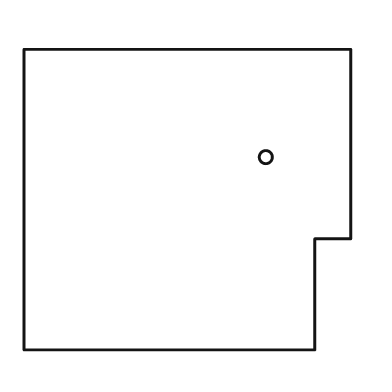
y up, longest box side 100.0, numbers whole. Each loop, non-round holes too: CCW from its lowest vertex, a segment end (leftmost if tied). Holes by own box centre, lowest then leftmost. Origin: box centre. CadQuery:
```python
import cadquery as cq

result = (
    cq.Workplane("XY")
    .moveTo(-50.0, -46.0)
    .lineTo(39.0, -46.0)
    .lineTo(39.0, -12.0)
    .lineTo(50.0, -12.0)
    .lineTo(50.0, 46.0)
    .lineTo(-50.0, 46.0)
    .close()
    .moveTo(24.0, 13.0)
    .circle(2.0)
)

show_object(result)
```